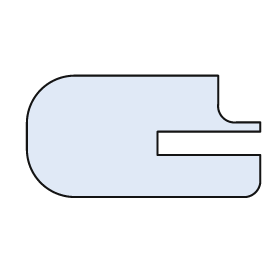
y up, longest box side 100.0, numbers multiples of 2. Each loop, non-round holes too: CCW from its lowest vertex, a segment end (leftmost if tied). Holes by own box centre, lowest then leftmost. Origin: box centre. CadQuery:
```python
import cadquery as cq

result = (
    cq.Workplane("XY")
    .moveTo(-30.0, -26.0)
    .lineTo(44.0, -26.0)
    .threePointArc((48.0, -24.0), (50.0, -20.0))
    .lineTo(50.0, -8.0)
    .lineTo(6.0, -8.0)
    .lineTo(6.0, 2.0)
    .lineTo(50.0, 2.0)
    .lineTo(50.0, 6.0)
    .lineTo(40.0, 6.0)
    .threePointArc((34.0, 8.0), (32.0, 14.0))
    .lineTo(32.0, 26.0)
    .lineTo(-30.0, 26.0)
    .threePointArc((-44.0, 20.0), (-50.0, 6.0))
    .lineTo(-50.0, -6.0)
    .threePointArc((-44.0, -20.0), (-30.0, -26.0))
    .close()
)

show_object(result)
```